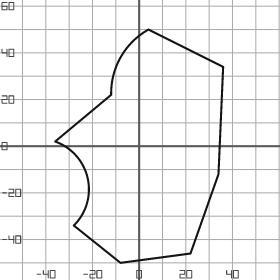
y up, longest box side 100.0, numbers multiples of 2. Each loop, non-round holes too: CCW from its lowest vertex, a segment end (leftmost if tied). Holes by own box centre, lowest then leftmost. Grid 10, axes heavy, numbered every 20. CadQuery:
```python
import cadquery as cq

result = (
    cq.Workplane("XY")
    .moveTo(-8.0, -50.0)
    .lineTo(22.0, -46.0)
    .lineTo(34.0, -12.0)
    .lineTo(36.0, 34.0)
    .lineTo(4.0, 50.0)
    .threePointArc((-8.0, 38.0), (-12.0, 22.0))
    .lineTo(-36.0, 2.0)
    .threePointArc((-22.0, -14.0), (-28.0, -34.0))
    .close()
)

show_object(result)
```